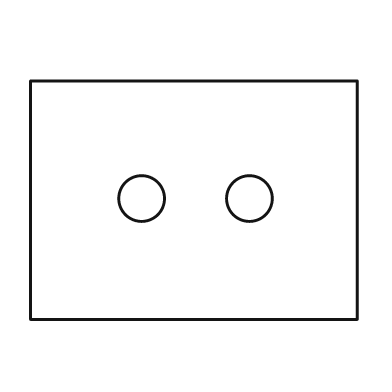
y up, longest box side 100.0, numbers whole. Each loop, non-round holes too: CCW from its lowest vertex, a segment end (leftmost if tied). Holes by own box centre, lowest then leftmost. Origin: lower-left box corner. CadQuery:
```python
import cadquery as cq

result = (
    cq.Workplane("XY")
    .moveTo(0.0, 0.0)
    .lineTo(100.0, 0.0)
    .lineTo(100.0, 73.0)
    .lineTo(0.0, 73.0)
    .close()
    .moveTo(34.0, 37.0)
    .circle(7.0)
    .moveTo(67.0, 37.0)
    .circle(7.0)
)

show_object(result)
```